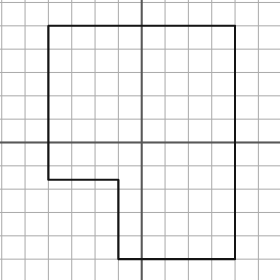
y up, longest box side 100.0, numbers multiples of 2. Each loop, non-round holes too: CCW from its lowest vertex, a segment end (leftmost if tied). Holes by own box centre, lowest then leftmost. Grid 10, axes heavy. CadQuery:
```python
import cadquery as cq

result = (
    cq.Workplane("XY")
    .moveTo(-10.0, -50.0)
    .lineTo(40.0, -50.0)
    .lineTo(40.0, 50.0)
    .lineTo(-40.0, 50.0)
    .lineTo(-40.0, -16.0)
    .lineTo(-10.0, -16.0)
    .close()
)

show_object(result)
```